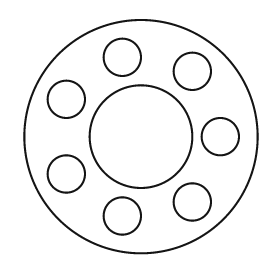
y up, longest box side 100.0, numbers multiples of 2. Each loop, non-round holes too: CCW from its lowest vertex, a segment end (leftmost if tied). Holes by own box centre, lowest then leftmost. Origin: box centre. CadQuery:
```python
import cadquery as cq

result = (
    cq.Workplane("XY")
    .moveTo(0.0, 0.0)
    .circle(50.0)
    .moveTo(-8.0, -34.0)
    .circle(8.0)
    .moveTo(22.0, -28.0)
    .circle(8.0)
    .moveTo(-32.0, -16.0)
    .circle(8.0)
    .moveTo(0.0, 0.0)
    .circle(22.0)
    .moveTo(34.0, 0.0)
    .circle(8.0)
    .moveTo(-32.0, 16.0)
    .circle(8.0)
    .moveTo(22.0, 28.0)
    .circle(8.0)
    .moveTo(-8.0, 34.0)
    .circle(8.0)
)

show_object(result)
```